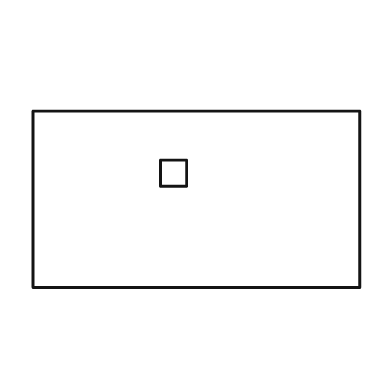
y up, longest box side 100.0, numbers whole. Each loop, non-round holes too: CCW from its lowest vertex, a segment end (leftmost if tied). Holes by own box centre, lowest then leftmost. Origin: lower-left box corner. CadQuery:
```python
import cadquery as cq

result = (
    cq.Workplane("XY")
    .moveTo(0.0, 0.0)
    .lineTo(100.0, 0.0)
    .lineTo(100.0, 54.0)
    .lineTo(0.0, 54.0)
    .close()
    .moveTo(39.0, 31.0)
    .lineTo(47.0, 31.0)
    .lineTo(47.0, 39.0)
    .lineTo(39.0, 39.0)
    .close()
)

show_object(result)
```